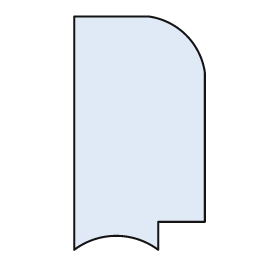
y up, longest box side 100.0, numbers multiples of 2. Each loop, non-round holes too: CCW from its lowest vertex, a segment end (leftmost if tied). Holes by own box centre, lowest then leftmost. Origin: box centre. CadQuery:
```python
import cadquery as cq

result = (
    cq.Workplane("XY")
    .moveTo(-28.0, -50.0)
    .threePointArc((-10.0, -44.0), (8.0, -50.0))
    .lineTo(8.0, -38.0)
    .lineTo(28.0, -38.0)
    .lineTo(28.0, 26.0)
    .threePointArc((20.0, 42.0), (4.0, 50.0))
    .lineTo(-28.0, 50.0)
    .close()
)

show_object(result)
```